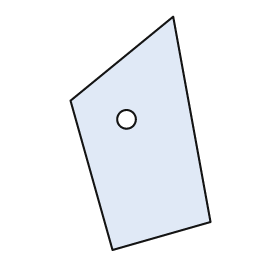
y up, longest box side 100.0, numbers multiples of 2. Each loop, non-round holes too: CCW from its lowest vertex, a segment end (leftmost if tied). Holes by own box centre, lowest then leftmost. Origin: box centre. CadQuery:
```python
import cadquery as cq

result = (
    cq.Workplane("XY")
    .moveTo(-12.0, -50.0)
    .lineTo(30.0, -38.0)
    .lineTo(14.0, 50.0)
    .lineTo(-30.0, 14.0)
    .close()
    .moveTo(-6.0, 6.0)
    .circle(4.0)
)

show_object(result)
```